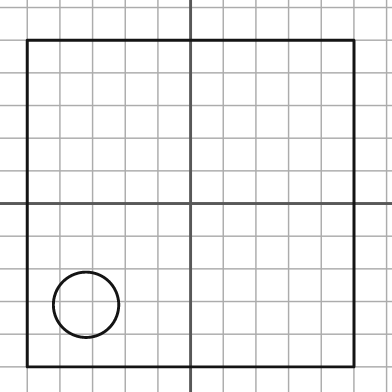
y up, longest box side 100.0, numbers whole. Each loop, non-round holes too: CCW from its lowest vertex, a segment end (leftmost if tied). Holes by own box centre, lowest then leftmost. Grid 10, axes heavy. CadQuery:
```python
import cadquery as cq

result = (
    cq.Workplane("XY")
    .moveTo(-50.0, -50.0)
    .lineTo(50.0, -50.0)
    .lineTo(50.0, 50.0)
    .lineTo(-50.0, 50.0)
    .close()
    .moveTo(-32.0, -31.0)
    .circle(10.0)
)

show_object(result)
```